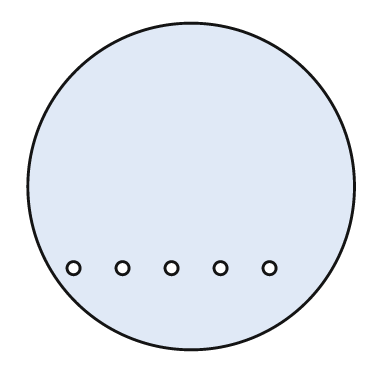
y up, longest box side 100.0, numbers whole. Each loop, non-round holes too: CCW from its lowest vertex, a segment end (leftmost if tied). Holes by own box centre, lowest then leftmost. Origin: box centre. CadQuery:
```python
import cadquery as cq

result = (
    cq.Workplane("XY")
    .moveTo(0.0, 0.0)
    .circle(50.0)
    .moveTo(-36.0, -25.0)
    .circle(2.0)
    .moveTo(-21.0, -25.0)
    .circle(2.0)
    .moveTo(-6.0, -25.0)
    .circle(2.0)
    .moveTo(9.0, -25.0)
    .circle(2.0)
    .moveTo(24.0, -25.0)
    .circle(2.0)
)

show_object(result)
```